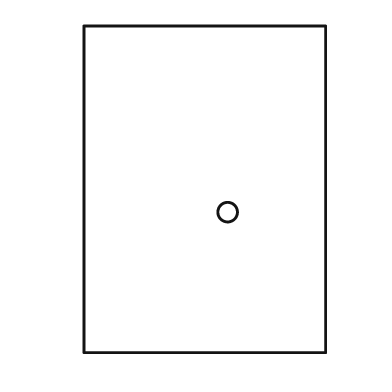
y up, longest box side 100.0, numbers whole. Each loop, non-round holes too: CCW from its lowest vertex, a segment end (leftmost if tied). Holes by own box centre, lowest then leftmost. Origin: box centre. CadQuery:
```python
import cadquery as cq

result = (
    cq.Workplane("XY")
    .moveTo(-37.0, -50.0)
    .lineTo(37.0, -50.0)
    .lineTo(37.0, 50.0)
    .lineTo(-37.0, 50.0)
    .close()
    .moveTo(7.0, -7.0)
    .circle(3.0)
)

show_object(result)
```